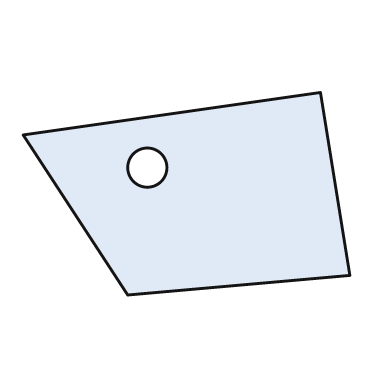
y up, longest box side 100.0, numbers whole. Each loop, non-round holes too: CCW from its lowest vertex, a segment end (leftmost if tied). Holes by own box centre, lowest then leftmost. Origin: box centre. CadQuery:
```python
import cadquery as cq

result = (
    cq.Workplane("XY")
    .moveTo(-18.0, -31.0)
    .lineTo(50.0, -25.0)
    .lineTo(41.0, 31.0)
    .lineTo(-50.0, 18.0)
    .close()
    .moveTo(-12.0, 8.0)
    .circle(6.0)
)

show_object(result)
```